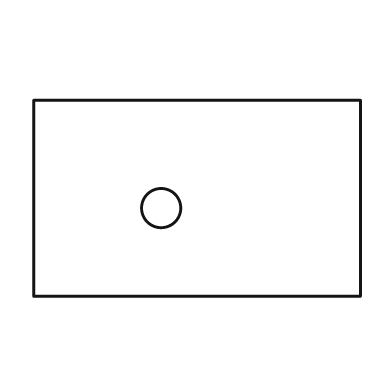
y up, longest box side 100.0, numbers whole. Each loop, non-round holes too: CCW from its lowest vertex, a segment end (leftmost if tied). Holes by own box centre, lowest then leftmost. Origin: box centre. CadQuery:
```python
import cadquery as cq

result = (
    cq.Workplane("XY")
    .moveTo(-50.0, -30.0)
    .lineTo(50.0, -30.0)
    .lineTo(50.0, 30.0)
    .lineTo(-50.0, 30.0)
    .close()
    .moveTo(-11.0, -3.0)
    .circle(6.0)
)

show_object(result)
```